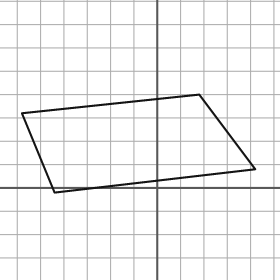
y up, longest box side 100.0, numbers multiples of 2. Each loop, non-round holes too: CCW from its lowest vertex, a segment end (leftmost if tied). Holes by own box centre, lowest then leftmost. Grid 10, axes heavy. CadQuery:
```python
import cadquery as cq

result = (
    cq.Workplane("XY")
    .moveTo(-44.0, -2.0)
    .lineTo(42.0, 8.0)
    .lineTo(18.0, 40.0)
    .lineTo(-58.0, 32.0)
    .close()
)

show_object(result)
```